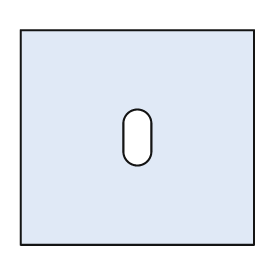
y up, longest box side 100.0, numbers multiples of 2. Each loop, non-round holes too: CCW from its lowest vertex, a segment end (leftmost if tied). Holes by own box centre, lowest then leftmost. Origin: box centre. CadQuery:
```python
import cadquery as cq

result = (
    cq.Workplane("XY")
    .moveTo(-50.0, -46.0)
    .lineTo(50.0, -46.0)
    .lineTo(50.0, 46.0)
    .lineTo(-50.0, 46.0)
    .close()
    .moveTo(-6.0, -6.0)
    .threePointArc((0.0, -12.0), (6.0, -6.0))
    .lineTo(6.0, 6.0)
    .threePointArc((0.0, 12.0), (-6.0, 6.0))
    .close()
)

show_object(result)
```